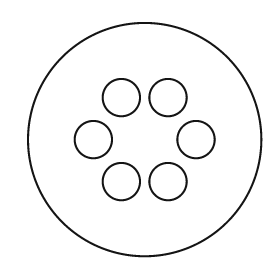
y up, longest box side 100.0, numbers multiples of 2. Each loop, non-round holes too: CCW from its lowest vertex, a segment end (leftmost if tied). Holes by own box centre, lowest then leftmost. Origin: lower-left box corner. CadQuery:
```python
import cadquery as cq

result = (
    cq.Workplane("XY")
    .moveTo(50.0, 50.0)
    .circle(50.0)
    .moveTo(40.0, 32.0)
    .circle(8.0)
    .moveTo(60.0, 32.0)
    .circle(8.0)
    .moveTo(28.0, 50.0)
    .circle(8.0)
    .moveTo(72.0, 50.0)
    .circle(8.0)
    .moveTo(40.0, 68.0)
    .circle(8.0)
    .moveTo(60.0, 68.0)
    .circle(8.0)
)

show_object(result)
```